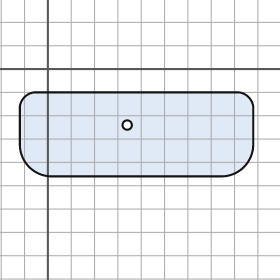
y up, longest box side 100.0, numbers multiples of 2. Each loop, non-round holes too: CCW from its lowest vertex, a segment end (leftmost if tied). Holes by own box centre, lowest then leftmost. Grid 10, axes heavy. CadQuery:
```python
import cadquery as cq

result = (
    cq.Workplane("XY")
    .moveTo(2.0, -46.0)
    .lineTo(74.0, -46.0)
    .threePointArc((84.0, -42.0), (88.0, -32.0))
    .lineTo(88.0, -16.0)
    .threePointArc((86.0, -12.0), (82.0, -10.0))
    .lineTo(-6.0, -10.0)
    .threePointArc((-10.0, -12.0), (-12.0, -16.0))
    .lineTo(-12.0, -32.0)
    .threePointArc((-8.0, -42.0), (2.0, -46.0))
    .close()
    .moveTo(34.0, -24.0)
    .circle(2.0)
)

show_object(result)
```